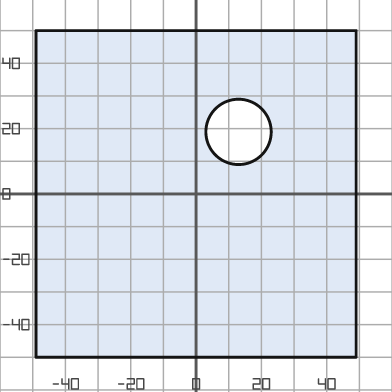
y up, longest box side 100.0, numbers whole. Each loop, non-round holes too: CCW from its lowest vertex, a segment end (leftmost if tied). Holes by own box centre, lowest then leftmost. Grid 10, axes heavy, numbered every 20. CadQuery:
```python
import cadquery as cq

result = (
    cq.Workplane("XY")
    .moveTo(-49.0, -50.0)
    .lineTo(49.0, -50.0)
    .lineTo(49.0, 50.0)
    .lineTo(-49.0, 50.0)
    .close()
    .moveTo(13.0, 19.0)
    .circle(10.0)
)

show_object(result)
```